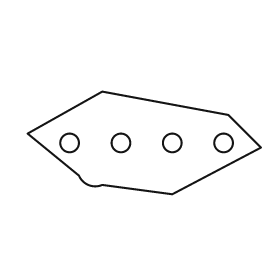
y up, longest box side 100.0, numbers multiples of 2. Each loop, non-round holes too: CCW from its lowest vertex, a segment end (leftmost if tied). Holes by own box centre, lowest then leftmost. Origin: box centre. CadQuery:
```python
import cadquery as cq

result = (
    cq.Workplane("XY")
    .moveTo(12.0, -22.0)
    .lineTo(50.0, -2.0)
    .lineTo(36.0, 12.0)
    .lineTo(-18.0, 22.0)
    .lineTo(-50.0, 4.0)
    .lineTo(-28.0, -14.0)
    .threePointArc((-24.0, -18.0), (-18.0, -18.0))
    .close()
    .moveTo(-32.0, 0.0)
    .circle(4.0)
    .moveTo(-10.0, 0.0)
    .circle(4.0)
    .moveTo(12.0, 0.0)
    .circle(4.0)
    .moveTo(34.0, 0.0)
    .circle(4.0)
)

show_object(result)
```